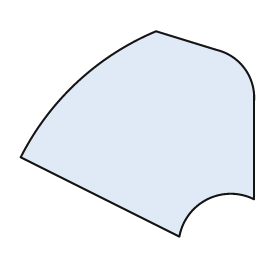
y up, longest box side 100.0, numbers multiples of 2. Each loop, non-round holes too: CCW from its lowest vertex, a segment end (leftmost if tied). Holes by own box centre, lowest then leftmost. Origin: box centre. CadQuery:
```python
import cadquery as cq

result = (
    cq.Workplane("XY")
    .moveTo(18.0, -44.0)
    .threePointArc((30.0, -28.0), (50.0, -28.0))
    .lineTo(50.0, 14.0)
    .threePointArc((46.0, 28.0), (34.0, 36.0))
    .lineTo(8.0, 44.0)
    .threePointArc((-26.0, 22.0), (-50.0, -10.0))
    .close()
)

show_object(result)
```